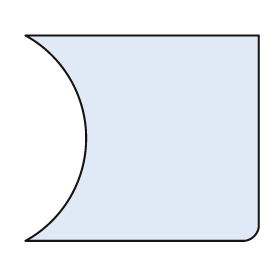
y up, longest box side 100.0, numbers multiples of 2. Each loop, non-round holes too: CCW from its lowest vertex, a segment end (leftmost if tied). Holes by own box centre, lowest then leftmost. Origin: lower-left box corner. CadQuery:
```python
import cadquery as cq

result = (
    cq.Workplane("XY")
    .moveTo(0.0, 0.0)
    .lineTo(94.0, 0.0)
    .threePointArc((98.0, 2.0), (100.0, 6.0))
    .lineTo(100.0, 88.0)
    .lineTo(0.0, 88.0)
    .threePointArc((26.0, 44.0), (0.0, 0.0))
    .close()
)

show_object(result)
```